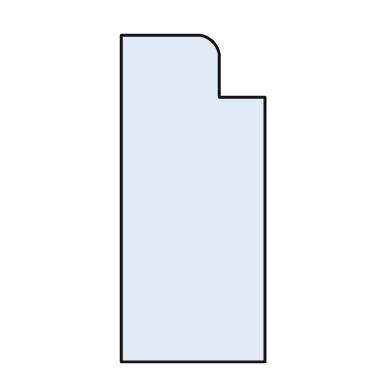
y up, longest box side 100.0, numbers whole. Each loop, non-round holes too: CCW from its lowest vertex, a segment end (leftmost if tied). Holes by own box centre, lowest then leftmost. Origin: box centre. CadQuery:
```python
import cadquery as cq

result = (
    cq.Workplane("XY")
    .moveTo(-22.0, -50.0)
    .lineTo(22.0, -50.0)
    .lineTo(22.0, 31.0)
    .lineTo(8.0, 31.0)
    .lineTo(8.0, 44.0)
    .threePointArc((6.0, 48.0), (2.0, 50.0))
    .lineTo(-22.0, 50.0)
    .close()
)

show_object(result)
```